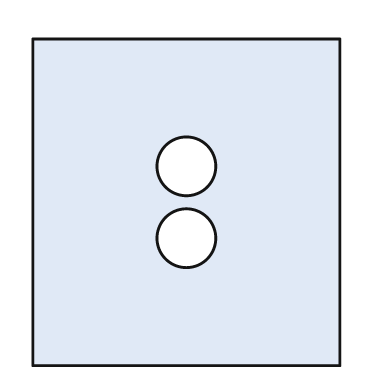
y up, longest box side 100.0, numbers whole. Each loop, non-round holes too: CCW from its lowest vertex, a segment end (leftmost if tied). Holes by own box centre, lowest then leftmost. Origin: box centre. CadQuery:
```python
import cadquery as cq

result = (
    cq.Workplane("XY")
    .moveTo(-47.0, -50.0)
    .lineTo(47.0, -50.0)
    .lineTo(47.0, 50.0)
    .lineTo(-47.0, 50.0)
    .close()
    .moveTo(0.0, -11.0)
    .circle(9.0)
    .moveTo(0.0, 11.0)
    .circle(9.0)
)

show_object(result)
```